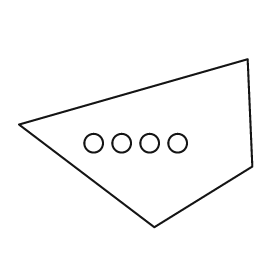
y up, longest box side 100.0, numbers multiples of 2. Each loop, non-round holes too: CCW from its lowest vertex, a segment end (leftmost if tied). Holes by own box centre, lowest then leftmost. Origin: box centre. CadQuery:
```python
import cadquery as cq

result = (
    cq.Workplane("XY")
    .moveTo(8.0, -36.0)
    .lineTo(50.0, -10.0)
    .lineTo(48.0, 36.0)
    .lineTo(-50.0, 8.0)
    .close()
    .moveTo(-18.0, 0.0)
    .circle(4.0)
    .moveTo(-6.0, 0.0)
    .circle(4.0)
    .moveTo(6.0, 0.0)
    .circle(4.0)
    .moveTo(18.0, 0.0)
    .circle(4.0)
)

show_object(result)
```